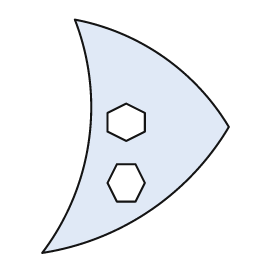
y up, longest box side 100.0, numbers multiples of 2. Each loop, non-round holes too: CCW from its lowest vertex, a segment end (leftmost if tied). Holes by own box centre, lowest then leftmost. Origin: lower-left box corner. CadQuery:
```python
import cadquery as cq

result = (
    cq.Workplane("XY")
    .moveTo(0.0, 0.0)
    .threePointArc((46.0, 18.0), (80.0, 54.0))
    .threePointArc((52.0, 84.0), (14.0, 100.0))
    .threePointArc((20.0, 48.0), (0.0, 0.0))
    .close()
    .moveTo(32.0, 22.0)
    .lineTo(40.0, 22.0)
    .lineTo(44.0, 30.0)
    .lineTo(40.0, 38.0)
    .lineTo(32.0, 38.0)
    .lineTo(28.0, 30.0)
    .close()
    .moveTo(36.0, 48.0)
    .lineTo(44.0, 52.0)
    .lineTo(44.0, 60.0)
    .lineTo(36.0, 64.0)
    .lineTo(28.0, 60.0)
    .lineTo(28.0, 52.0)
    .close()
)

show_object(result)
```